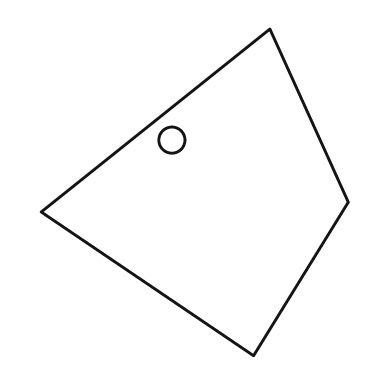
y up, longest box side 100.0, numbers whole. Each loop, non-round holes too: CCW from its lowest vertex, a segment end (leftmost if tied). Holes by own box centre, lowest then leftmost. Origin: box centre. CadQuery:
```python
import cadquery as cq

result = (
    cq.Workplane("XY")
    .moveTo(18.0, -50.0)
    .lineTo(47.0, -3.0)
    .lineTo(23.0, 50.0)
    .lineTo(-47.0, -6.0)
    .close()
    .moveTo(-7.0, 16.0)
    .circle(4.0)
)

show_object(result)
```